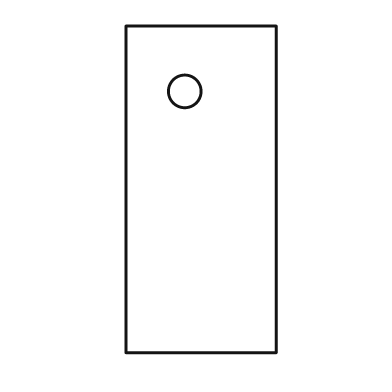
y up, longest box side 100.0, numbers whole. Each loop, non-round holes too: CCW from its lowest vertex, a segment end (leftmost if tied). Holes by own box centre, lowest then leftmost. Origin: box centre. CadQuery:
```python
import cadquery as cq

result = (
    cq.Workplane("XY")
    .moveTo(-23.0, -50.0)
    .lineTo(23.0, -50.0)
    .lineTo(23.0, 50.0)
    .lineTo(-23.0, 50.0)
    .close()
    .moveTo(-5.0, 30.0)
    .circle(5.0)
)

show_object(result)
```